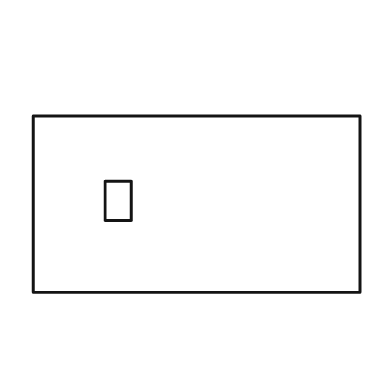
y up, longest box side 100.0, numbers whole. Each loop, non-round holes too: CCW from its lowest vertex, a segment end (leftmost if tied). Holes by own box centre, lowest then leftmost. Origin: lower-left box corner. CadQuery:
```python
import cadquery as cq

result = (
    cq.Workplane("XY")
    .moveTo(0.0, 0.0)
    .lineTo(100.0, 0.0)
    .lineTo(100.0, 54.0)
    .lineTo(0.0, 54.0)
    .close()
    .moveTo(22.0, 22.0)
    .lineTo(30.0, 22.0)
    .lineTo(30.0, 34.0)
    .lineTo(22.0, 34.0)
    .close()
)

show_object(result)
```